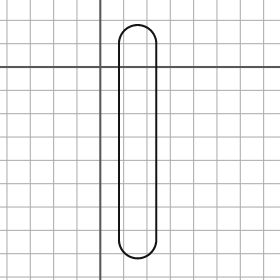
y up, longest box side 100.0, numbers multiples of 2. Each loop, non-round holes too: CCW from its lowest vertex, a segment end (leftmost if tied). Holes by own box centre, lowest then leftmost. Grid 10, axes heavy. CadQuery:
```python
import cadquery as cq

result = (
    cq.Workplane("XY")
    .moveTo(8.0, -74.0)
    .threePointArc((16.0, -82.0), (24.0, -74.0))
    .lineTo(24.0, 10.0)
    .threePointArc((16.0, 18.0), (8.0, 10.0))
    .close()
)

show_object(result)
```